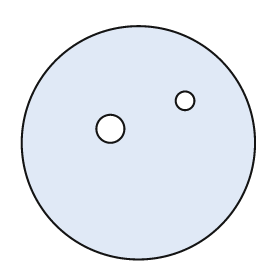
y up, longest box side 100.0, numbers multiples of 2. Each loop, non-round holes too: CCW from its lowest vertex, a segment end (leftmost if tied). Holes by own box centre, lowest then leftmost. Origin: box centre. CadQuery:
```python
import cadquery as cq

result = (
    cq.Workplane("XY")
    .moveTo(0.0, 0.0)
    .circle(50.0)
    .moveTo(-12.0, 6.0)
    .circle(6.0)
    .moveTo(20.0, 18.0)
    .circle(4.0)
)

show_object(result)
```